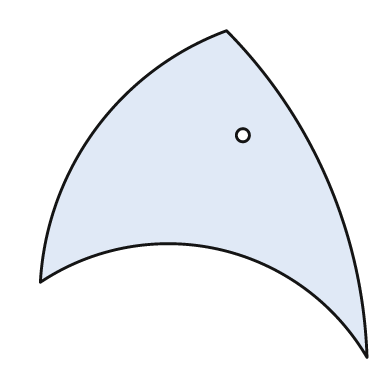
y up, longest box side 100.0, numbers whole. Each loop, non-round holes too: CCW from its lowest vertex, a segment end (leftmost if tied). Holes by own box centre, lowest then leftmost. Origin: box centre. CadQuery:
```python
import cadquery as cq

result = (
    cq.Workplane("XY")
    .moveTo(50.0, -50.0)
    .threePointArc((38.0, 4.0), (7.0, 50.0))
    .threePointArc((-33.0, 20.0), (-50.0, -27.0))
    .threePointArc((5.0, -17.0), (50.0, -50.0))
    .close()
    .moveTo(12.0, 18.0)
    .circle(2.0)
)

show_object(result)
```